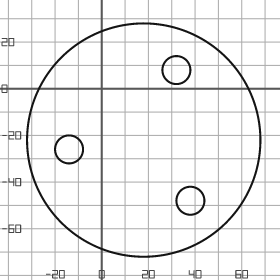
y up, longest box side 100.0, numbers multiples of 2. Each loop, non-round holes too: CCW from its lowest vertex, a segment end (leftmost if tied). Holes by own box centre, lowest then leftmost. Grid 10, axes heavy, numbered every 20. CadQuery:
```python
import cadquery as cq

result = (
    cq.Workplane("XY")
    .moveTo(18.0, -22.0)
    .circle(50.0)
    .moveTo(38.0, -48.0)
    .circle(6.0)
    .moveTo(-14.0, -26.0)
    .circle(6.0)
    .moveTo(32.0, 8.0)
    .circle(6.0)
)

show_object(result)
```